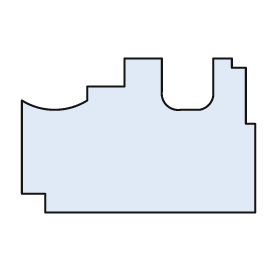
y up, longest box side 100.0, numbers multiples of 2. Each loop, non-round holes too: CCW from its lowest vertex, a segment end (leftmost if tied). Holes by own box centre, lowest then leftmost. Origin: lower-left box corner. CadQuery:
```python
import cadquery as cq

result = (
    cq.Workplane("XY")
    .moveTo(10.0, 0.0)
    .lineTo(100.0, 0.0)
    .lineTo(100.0, 38.0)
    .lineTo(96.0, 38.0)
    .lineTo(96.0, 62.0)
    .lineTo(90.0, 62.0)
    .lineTo(90.0, 66.0)
    .lineTo(82.0, 66.0)
    .lineTo(82.0, 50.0)
    .threePointArc((80.0, 46.0), (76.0, 44.0))
    .lineTo(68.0, 44.0)
    .threePointArc((62.0, 46.0), (60.0, 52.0))
    .lineTo(60.0, 66.0)
    .lineTo(44.0, 66.0)
    .lineTo(44.0, 54.0)
    .lineTo(28.0, 54.0)
    .lineTo(28.0, 48.0)
    .threePointArc((14.0, 44.0), (0.0, 48.0))
    .lineTo(0.0, 8.0)
    .lineTo(10.0, 8.0)
    .close()
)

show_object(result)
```